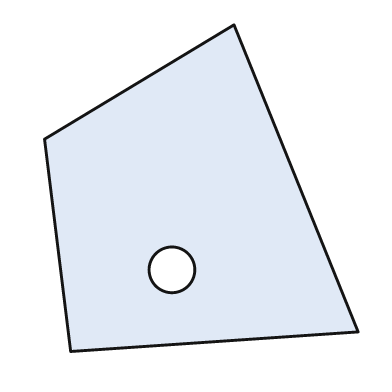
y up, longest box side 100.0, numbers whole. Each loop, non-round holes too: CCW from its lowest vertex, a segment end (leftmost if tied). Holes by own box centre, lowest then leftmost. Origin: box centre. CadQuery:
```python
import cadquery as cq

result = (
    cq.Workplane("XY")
    .moveTo(-40.0, -50.0)
    .lineTo(48.0, -44.0)
    .lineTo(10.0, 50.0)
    .lineTo(-48.0, 15.0)
    .close()
    .moveTo(-9.0, -25.0)
    .circle(7.0)
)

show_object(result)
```